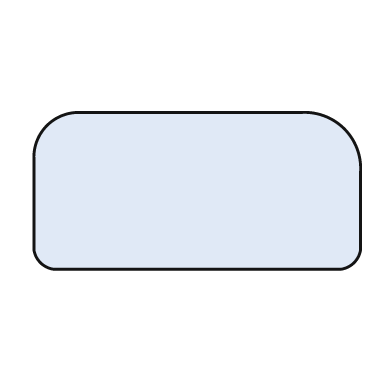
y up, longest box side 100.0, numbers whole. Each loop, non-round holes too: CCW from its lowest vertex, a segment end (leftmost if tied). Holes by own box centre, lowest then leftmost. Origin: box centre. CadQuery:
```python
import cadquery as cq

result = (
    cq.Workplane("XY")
    .moveTo(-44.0, -24.0)
    .lineTo(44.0, -24.0)
    .threePointArc((48.0, -22.0), (50.0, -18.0))
    .lineTo(50.0, 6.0)
    .threePointArc((45.0, 19.0), (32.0, 24.0))
    .lineTo(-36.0, 24.0)
    .threePointArc((-46.0, 20.0), (-50.0, 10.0))
    .lineTo(-50.0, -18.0)
    .threePointArc((-48.0, -22.0), (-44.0, -24.0))
    .close()
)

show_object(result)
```